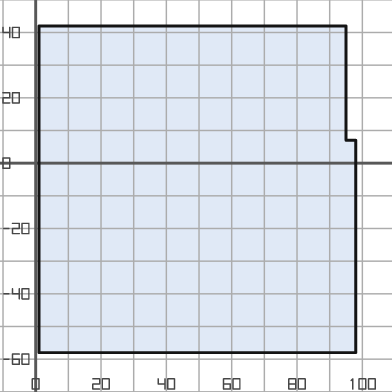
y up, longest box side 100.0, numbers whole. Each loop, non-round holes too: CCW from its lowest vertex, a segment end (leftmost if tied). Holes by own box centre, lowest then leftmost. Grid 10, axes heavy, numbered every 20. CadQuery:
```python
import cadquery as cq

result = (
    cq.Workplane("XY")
    .moveTo(1.0, -58.0)
    .lineTo(98.0, -58.0)
    .lineTo(98.0, 7.0)
    .lineTo(95.0, 7.0)
    .lineTo(95.0, 42.0)
    .lineTo(1.0, 42.0)
    .close()
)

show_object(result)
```